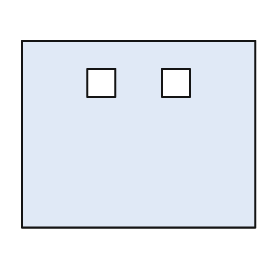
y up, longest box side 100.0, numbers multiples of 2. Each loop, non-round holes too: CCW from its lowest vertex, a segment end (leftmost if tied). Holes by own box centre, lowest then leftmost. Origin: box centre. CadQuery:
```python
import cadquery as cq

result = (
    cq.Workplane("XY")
    .moveTo(-50.0, -40.0)
    .lineTo(50.0, -40.0)
    .lineTo(50.0, 40.0)
    .lineTo(-50.0, 40.0)
    .close()
    .moveTo(-22.0, 16.0)
    .lineTo(-10.0, 16.0)
    .lineTo(-10.0, 28.0)
    .lineTo(-22.0, 28.0)
    .close()
    .moveTo(10.0, 16.0)
    .lineTo(22.0, 16.0)
    .lineTo(22.0, 28.0)
    .lineTo(10.0, 28.0)
    .close()
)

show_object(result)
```